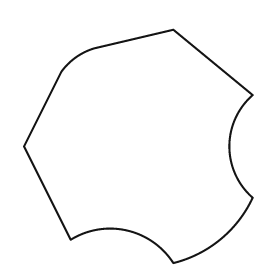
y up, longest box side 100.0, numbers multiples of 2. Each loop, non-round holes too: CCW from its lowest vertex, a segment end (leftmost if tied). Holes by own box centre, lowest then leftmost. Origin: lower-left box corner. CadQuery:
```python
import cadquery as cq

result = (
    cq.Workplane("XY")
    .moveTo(64.0, 0.0)
    .threePointArc((84.0, 10.0), (98.0, 28.0))
    .threePointArc((88.0, 50.0), (98.0, 72.0))
    .lineTo(64.0, 100.0)
    .lineTo(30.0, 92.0)
    .threePointArc((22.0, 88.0), (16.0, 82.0))
    .lineTo(0.0, 50.0)
    .lineTo(20.0, 10.0)
    .threePointArc((44.0, 14.0), (64.0, 0.0))
    .close()
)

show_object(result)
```